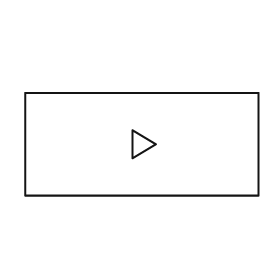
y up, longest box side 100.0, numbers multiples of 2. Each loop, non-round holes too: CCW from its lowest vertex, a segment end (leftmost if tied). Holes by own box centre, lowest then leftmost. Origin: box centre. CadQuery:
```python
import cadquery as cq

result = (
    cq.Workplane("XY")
    .moveTo(-50.0, -22.0)
    .lineTo(50.0, -22.0)
    .lineTo(50.0, 22.0)
    .lineTo(-50.0, 22.0)
    .close()
    .moveTo(-4.0, -6.0)
    .lineTo(6.0, 0.0)
    .lineTo(-4.0, 6.0)
    .close()
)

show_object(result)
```